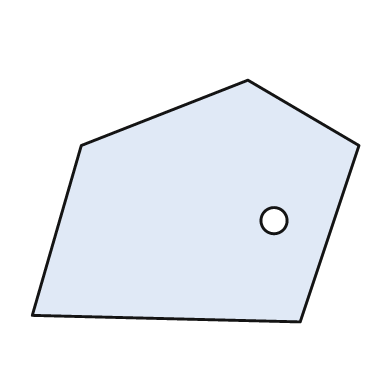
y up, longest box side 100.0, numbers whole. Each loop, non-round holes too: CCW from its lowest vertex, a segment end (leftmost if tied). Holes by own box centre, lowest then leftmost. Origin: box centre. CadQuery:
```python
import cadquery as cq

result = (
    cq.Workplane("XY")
    .moveTo(32.0, -37.0)
    .lineTo(50.0, 17.0)
    .lineTo(16.0, 37.0)
    .lineTo(-35.0, 17.0)
    .lineTo(-50.0, -35.0)
    .close()
    .moveTo(24.0, -6.0)
    .circle(4.0)
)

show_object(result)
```